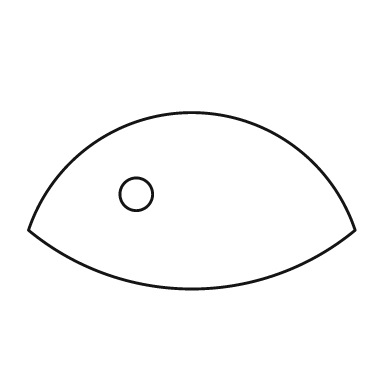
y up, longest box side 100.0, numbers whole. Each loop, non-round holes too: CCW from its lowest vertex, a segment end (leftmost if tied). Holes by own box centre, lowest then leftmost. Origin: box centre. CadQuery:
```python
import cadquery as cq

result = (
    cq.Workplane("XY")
    .moveTo(-50.0, -9.0)
    .threePointArc((0.0, -27.0), (50.0, -9.0))
    .threePointArc((0.0, 27.0), (-50.0, -9.0))
    .close()
    .moveTo(-17.0, 2.0)
    .circle(5.0)
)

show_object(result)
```